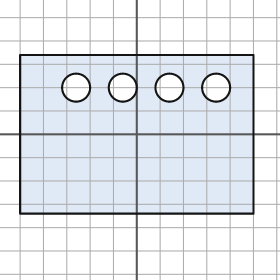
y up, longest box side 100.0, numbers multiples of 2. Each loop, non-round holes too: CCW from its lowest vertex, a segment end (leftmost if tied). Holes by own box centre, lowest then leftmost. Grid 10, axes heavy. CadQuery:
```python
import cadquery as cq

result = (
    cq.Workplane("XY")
    .moveTo(-50.0, -34.0)
    .lineTo(50.0, -34.0)
    .lineTo(50.0, 34.0)
    .lineTo(-50.0, 34.0)
    .close()
    .moveTo(-26.0, 20.0)
    .circle(6.0)
    .moveTo(-6.0, 20.0)
    .circle(6.0)
    .moveTo(14.0, 20.0)
    .circle(6.0)
    .moveTo(34.0, 20.0)
    .circle(6.0)
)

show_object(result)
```